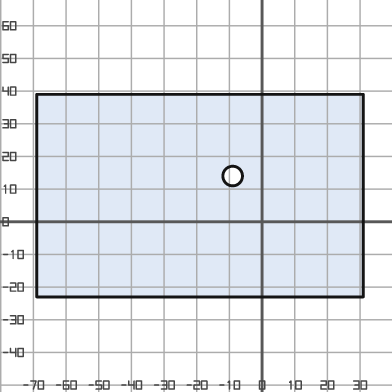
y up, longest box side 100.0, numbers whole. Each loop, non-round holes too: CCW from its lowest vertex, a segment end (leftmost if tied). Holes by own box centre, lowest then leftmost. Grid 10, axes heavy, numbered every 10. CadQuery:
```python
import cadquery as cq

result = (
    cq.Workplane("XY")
    .moveTo(-69.0, -23.0)
    .lineTo(31.0, -23.0)
    .lineTo(31.0, 39.0)
    .lineTo(-69.0, 39.0)
    .close()
    .moveTo(-9.0, 14.0)
    .circle(3.0)
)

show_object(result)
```